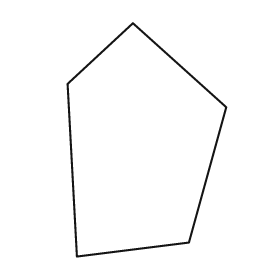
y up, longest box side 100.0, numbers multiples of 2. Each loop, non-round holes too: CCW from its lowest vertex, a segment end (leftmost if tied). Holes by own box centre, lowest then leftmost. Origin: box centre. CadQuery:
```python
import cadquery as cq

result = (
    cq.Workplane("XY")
    .moveTo(-30.0, -50.0)
    .lineTo(18.0, -44.0)
    .lineTo(34.0, 14.0)
    .lineTo(-6.0, 50.0)
    .lineTo(-34.0, 24.0)
    .close()
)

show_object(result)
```